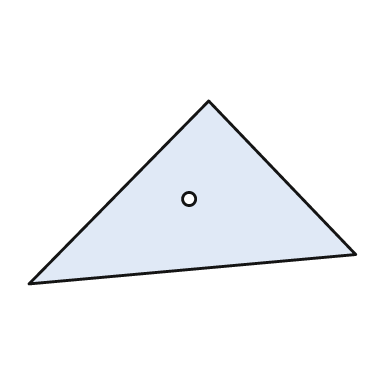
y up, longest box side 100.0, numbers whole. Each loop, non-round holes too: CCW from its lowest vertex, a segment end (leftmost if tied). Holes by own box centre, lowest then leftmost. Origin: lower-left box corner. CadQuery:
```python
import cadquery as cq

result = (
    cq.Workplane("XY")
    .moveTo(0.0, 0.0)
    .lineTo(100.0, 9.0)
    .lineTo(55.0, 56.0)
    .close()
    .moveTo(49.0, 26.0)
    .circle(2.0)
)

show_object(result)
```